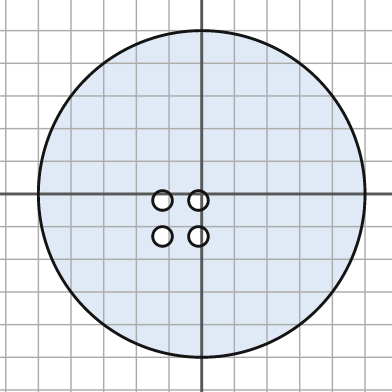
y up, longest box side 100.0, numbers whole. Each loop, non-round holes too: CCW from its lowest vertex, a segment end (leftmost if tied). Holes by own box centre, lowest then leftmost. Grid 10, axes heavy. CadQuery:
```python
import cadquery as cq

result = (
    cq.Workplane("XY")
    .moveTo(0.0, 0.0)
    .circle(50.0)
    .moveTo(-12.0, -13.0)
    .circle(3.0)
    .moveTo(-1.0, -13.0)
    .circle(3.0)
    .moveTo(-12.0, -2.0)
    .circle(3.0)
    .moveTo(-1.0, -2.0)
    .circle(3.0)
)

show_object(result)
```